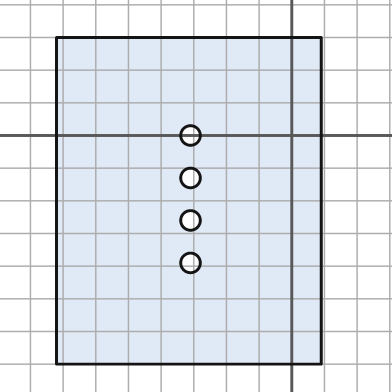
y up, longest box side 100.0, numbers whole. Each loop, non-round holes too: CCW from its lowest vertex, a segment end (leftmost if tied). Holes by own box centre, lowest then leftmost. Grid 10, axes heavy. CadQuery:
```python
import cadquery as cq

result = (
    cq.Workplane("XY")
    .moveTo(-72.0, -70.0)
    .lineTo(9.0, -70.0)
    .lineTo(9.0, 30.0)
    .lineTo(-72.0, 30.0)
    .close()
    .moveTo(-31.0, -39.0)
    .circle(3.0)
    .moveTo(-31.0, -26.0)
    .circle(3.0)
    .moveTo(-31.0, -13.0)
    .circle(3.0)
    .moveTo(-31.0, 0.0)
    .circle(3.0)
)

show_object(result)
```